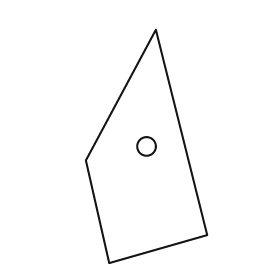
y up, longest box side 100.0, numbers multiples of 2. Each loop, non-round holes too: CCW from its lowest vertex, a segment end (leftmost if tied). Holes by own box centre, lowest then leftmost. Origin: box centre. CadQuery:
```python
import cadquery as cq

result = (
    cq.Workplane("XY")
    .moveTo(-16.0, -50.0)
    .lineTo(26.0, -38.0)
    .lineTo(4.0, 50.0)
    .lineTo(-26.0, -6.0)
    .close()
    .moveTo(0.0, 0.0)
    .circle(4.0)
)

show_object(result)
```